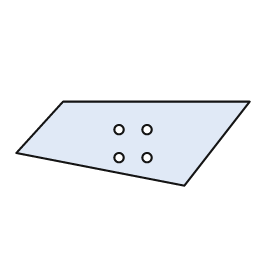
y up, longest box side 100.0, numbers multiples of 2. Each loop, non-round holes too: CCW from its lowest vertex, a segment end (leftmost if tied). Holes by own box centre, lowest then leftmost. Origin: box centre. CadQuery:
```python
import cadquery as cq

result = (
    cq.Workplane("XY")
    .moveTo(22.0, -18.0)
    .lineTo(50.0, 18.0)
    .lineTo(-30.0, 18.0)
    .lineTo(-50.0, -4.0)
    .close()
    .moveTo(-6.0, -6.0)
    .circle(2.0)
    .moveTo(6.0, -6.0)
    .circle(2.0)
    .moveTo(-6.0, 6.0)
    .circle(2.0)
    .moveTo(6.0, 6.0)
    .circle(2.0)
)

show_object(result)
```